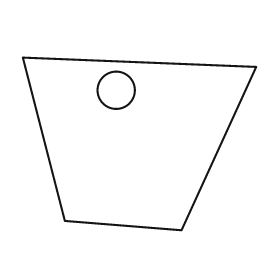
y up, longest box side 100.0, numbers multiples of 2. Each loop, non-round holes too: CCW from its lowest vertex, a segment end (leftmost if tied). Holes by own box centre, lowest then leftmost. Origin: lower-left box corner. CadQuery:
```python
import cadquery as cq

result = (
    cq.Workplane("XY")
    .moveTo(68.0, 0.0)
    .lineTo(100.0, 70.0)
    .lineTo(0.0, 74.0)
    .lineTo(18.0, 4.0)
    .close()
    .moveTo(40.0, 60.0)
    .circle(8.0)
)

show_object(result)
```